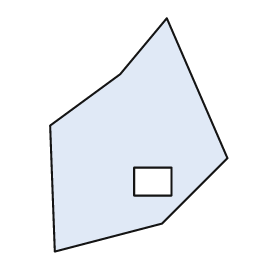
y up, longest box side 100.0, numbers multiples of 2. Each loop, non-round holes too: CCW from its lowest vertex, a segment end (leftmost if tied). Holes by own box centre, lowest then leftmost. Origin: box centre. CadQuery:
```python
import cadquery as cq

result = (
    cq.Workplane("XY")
    .moveTo(-36.0, -50.0)
    .lineTo(10.0, -38.0)
    .lineTo(38.0, -10.0)
    .lineTo(12.0, 50.0)
    .lineTo(-8.0, 26.0)
    .lineTo(-38.0, 4.0)
    .close()
    .moveTo(-2.0, -26.0)
    .lineTo(14.0, -26.0)
    .lineTo(14.0, -14.0)
    .lineTo(-2.0, -14.0)
    .close()
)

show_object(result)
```